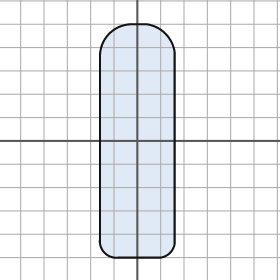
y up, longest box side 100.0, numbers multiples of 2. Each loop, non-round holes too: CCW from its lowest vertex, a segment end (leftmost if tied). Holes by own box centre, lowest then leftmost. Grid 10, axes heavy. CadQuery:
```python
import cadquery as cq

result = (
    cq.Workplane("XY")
    .moveTo(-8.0, -50.0)
    .lineTo(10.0, -50.0)
    .threePointArc((14.0, -48.0), (16.0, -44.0))
    .lineTo(16.0, 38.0)
    .threePointArc((12.0, 46.0), (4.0, 50.0))
    .lineTo(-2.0, 50.0)
    .threePointArc((-12.0, 46.0), (-16.0, 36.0))
    .lineTo(-16.0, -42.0)
    .threePointArc((-14.0, -48.0), (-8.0, -50.0))
    .close()
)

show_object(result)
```